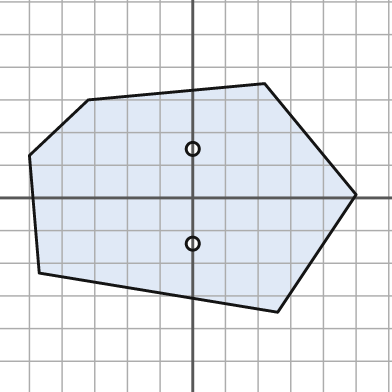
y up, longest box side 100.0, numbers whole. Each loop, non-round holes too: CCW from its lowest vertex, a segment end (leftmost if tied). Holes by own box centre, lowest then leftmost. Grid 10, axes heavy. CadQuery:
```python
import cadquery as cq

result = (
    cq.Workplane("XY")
    .moveTo(26.0, -35.0)
    .lineTo(50.0, 1.0)
    .lineTo(22.0, 35.0)
    .lineTo(-32.0, 30.0)
    .lineTo(-50.0, 13.0)
    .lineTo(-47.0, -23.0)
    .close()
    .moveTo(0.0, -14.0)
    .circle(2.0)
    .moveTo(0.0, 15.0)
    .circle(2.0)
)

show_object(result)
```